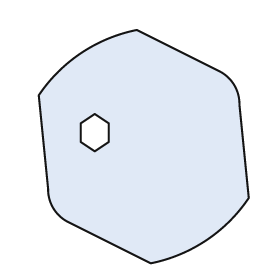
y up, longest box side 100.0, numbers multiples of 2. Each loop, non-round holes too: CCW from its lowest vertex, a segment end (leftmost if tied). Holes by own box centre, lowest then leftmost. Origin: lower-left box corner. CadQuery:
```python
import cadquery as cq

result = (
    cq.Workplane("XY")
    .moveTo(48.0, 0.0)
    .threePointArc((72.0, 10.0), (90.0, 28.0))
    .lineTo(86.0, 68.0)
    .threePointArc((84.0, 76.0), (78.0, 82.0))
    .lineTo(42.0, 100.0)
    .threePointArc((18.0, 90.0), (0.0, 72.0))
    .lineTo(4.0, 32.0)
    .threePointArc((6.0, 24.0), (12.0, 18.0))
    .close()
    .moveTo(24.0, 48.0)
    .lineTo(30.0, 52.0)
    .lineTo(30.0, 60.0)
    .lineTo(24.0, 64.0)
    .lineTo(18.0, 60.0)
    .lineTo(18.0, 52.0)
    .close()
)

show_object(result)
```